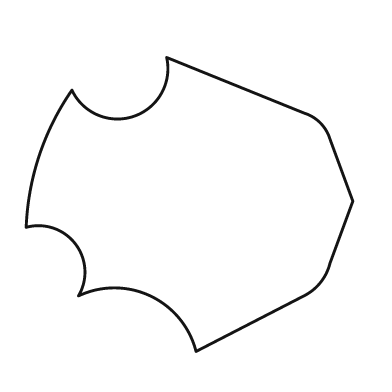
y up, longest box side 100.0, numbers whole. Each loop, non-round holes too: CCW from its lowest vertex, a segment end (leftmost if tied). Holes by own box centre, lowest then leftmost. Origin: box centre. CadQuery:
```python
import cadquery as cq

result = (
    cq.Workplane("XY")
    .moveTo(2.0, -45.0)
    .lineTo(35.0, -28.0)
    .threePointArc((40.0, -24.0), (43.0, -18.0))
    .lineTo(50.0, 1.0)
    .lineTo(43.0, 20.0)
    .threePointArc((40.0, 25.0), (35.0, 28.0))
    .lineTo(-7.0, 45.0)
    .threePointArc((-17.0, 27.0), (-36.0, 35.0))
    .threePointArc((-46.0, 15.0), (-50.0, -7.0))
    .threePointArc((-35.0, -12.0), (-34.0, -28.0))
    .threePointArc((-12.0, -28.0), (2.0, -45.0))
    .close()
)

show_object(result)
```